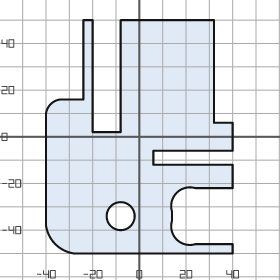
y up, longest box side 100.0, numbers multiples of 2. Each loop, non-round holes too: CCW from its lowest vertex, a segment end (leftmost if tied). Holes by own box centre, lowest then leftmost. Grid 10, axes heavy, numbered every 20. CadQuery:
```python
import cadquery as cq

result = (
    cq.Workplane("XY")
    .moveTo(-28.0, -50.0)
    .lineTo(40.0, -50.0)
    .lineTo(40.0, -46.0)
    .lineTo(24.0, -46.0)
    .threePointArc((16.0, -44.0), (14.0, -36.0))
    .lineTo(14.0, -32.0)
    .threePointArc((16.0, -24.0), (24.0, -22.0))
    .lineTo(40.0, -22.0)
    .lineTo(40.0, -12.0)
    .lineTo(6.0, -12.0)
    .lineTo(6.0, -6.0)
    .lineTo(40.0, -6.0)
    .lineTo(40.0, 6.0)
    .lineTo(32.0, 6.0)
    .lineTo(32.0, 50.0)
    .lineTo(-8.0, 50.0)
    .lineTo(-8.0, 2.0)
    .lineTo(-20.0, 2.0)
    .lineTo(-20.0, 50.0)
    .lineTo(-24.0, 50.0)
    .lineTo(-24.0, 16.0)
    .lineTo(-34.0, 16.0)
    .threePointArc((-38.0, 14.0), (-40.0, 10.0))
    .lineTo(-40.0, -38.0)
    .threePointArc((-36.0, -46.0), (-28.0, -50.0))
    .close()
    .moveTo(-8.0, -34.0)
    .circle(6.0)
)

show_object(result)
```